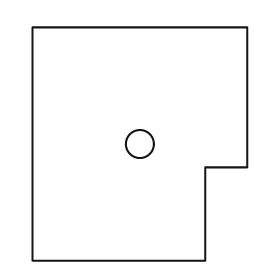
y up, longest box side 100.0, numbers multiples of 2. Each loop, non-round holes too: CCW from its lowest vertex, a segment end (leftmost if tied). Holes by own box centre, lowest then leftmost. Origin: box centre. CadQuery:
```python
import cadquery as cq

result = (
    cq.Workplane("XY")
    .moveTo(-46.0, -50.0)
    .lineTo(28.0, -50.0)
    .lineTo(28.0, -10.0)
    .lineTo(46.0, -10.0)
    .lineTo(46.0, 50.0)
    .lineTo(-46.0, 50.0)
    .close()
    .moveTo(0.0, 0.0)
    .circle(6.0)
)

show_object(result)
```